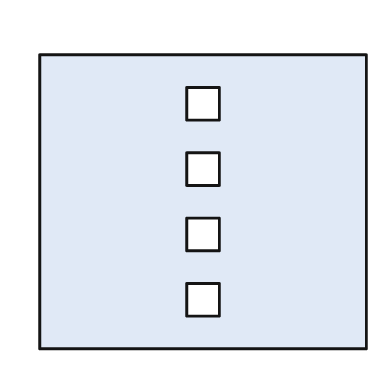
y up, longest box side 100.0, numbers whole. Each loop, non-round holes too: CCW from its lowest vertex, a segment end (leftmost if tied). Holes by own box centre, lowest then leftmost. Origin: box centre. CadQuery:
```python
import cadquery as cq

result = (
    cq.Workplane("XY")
    .moveTo(-50.0, -45.0)
    .lineTo(50.0, -45.0)
    .lineTo(50.0, 45.0)
    .lineTo(-50.0, 45.0)
    .close()
    .moveTo(-5.0, -35.0)
    .lineTo(5.0, -35.0)
    .lineTo(5.0, -25.0)
    .lineTo(-5.0, -25.0)
    .close()
    .moveTo(-5.0, -15.0)
    .lineTo(5.0, -15.0)
    .lineTo(5.0, -5.0)
    .lineTo(-5.0, -5.0)
    .close()
    .moveTo(-5.0, 5.0)
    .lineTo(5.0, 5.0)
    .lineTo(5.0, 15.0)
    .lineTo(-5.0, 15.0)
    .close()
    .moveTo(-5.0, 25.0)
    .lineTo(5.0, 25.0)
    .lineTo(5.0, 35.0)
    .lineTo(-5.0, 35.0)
    .close()
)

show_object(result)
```